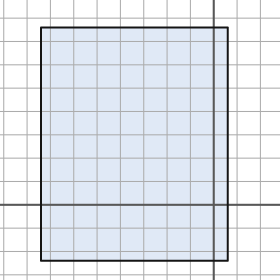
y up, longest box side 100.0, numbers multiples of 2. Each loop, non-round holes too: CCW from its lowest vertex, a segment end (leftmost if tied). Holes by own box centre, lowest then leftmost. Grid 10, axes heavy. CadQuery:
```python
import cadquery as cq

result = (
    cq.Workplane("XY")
    .moveTo(-74.0, -24.0)
    .lineTo(6.0, -24.0)
    .lineTo(6.0, 76.0)
    .lineTo(-74.0, 76.0)
    .close()
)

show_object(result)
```